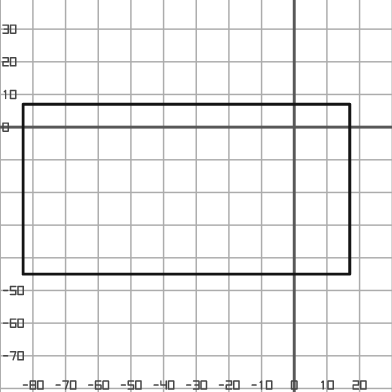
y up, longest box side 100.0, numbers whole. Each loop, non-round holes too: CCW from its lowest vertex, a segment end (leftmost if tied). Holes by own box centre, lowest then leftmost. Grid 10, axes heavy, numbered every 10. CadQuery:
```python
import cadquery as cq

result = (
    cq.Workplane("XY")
    .moveTo(-83.0, -45.0)
    .lineTo(17.0, -45.0)
    .lineTo(17.0, 7.0)
    .lineTo(-83.0, 7.0)
    .close()
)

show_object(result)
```